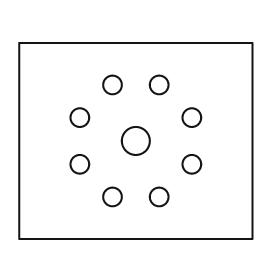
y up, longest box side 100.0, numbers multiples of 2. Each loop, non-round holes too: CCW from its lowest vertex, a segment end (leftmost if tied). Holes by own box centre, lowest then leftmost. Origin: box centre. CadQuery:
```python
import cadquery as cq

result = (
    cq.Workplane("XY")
    .moveTo(-50.0, -42.0)
    .lineTo(50.0, -42.0)
    .lineTo(50.0, 42.0)
    .lineTo(-50.0, 42.0)
    .close()
    .moveTo(-10.0, -24.0)
    .circle(4.0)
    .moveTo(10.0, -24.0)
    .circle(4.0)
    .moveTo(-24.0, -10.0)
    .circle(4.0)
    .moveTo(24.0, -10.0)
    .circle(4.0)
    .moveTo(0.0, 0.0)
    .circle(6.0)
    .moveTo(-24.0, 10.0)
    .circle(4.0)
    .moveTo(24.0, 10.0)
    .circle(4.0)
    .moveTo(-10.0, 24.0)
    .circle(4.0)
    .moveTo(10.0, 24.0)
    .circle(4.0)
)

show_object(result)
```